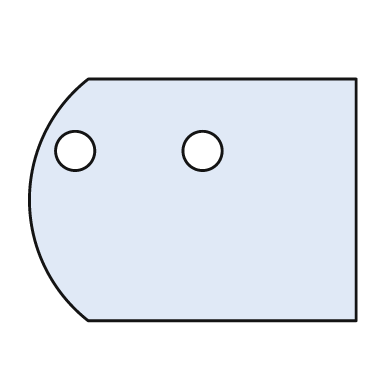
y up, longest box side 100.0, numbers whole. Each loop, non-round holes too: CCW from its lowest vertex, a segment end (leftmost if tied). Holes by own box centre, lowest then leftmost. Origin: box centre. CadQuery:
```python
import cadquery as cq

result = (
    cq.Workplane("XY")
    .moveTo(-32.0, -37.0)
    .lineTo(50.0, -37.0)
    .lineTo(50.0, 37.0)
    .lineTo(-32.0, 37.0)
    .threePointArc((-50.0, 0.0), (-32.0, -37.0))
    .close()
    .moveTo(-36.0, 15.0)
    .circle(6.0)
    .moveTo(3.0, 15.0)
    .circle(6.0)
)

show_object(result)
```